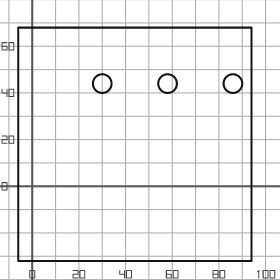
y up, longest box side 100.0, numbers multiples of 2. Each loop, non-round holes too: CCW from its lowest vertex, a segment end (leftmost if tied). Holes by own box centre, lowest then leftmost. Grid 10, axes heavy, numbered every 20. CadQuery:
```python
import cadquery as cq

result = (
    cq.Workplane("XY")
    .moveTo(-6.0, -32.0)
    .lineTo(94.0, -32.0)
    .lineTo(94.0, 68.0)
    .lineTo(-6.0, 68.0)
    .close()
    .moveTo(30.0, 44.0)
    .circle(4.0)
    .moveTo(58.0, 44.0)
    .circle(4.0)
    .moveTo(86.0, 44.0)
    .circle(4.0)
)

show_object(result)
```